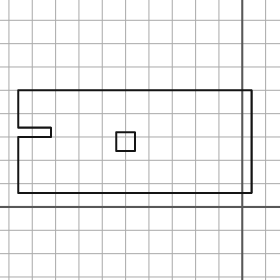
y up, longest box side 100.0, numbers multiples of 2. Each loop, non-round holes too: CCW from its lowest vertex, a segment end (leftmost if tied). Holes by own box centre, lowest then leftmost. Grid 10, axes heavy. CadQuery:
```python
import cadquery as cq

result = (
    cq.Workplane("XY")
    .moveTo(-96.0, 6.0)
    .lineTo(4.0, 6.0)
    .lineTo(4.0, 50.0)
    .lineTo(-96.0, 50.0)
    .lineTo(-96.0, 34.0)
    .lineTo(-82.0, 34.0)
    .lineTo(-82.0, 30.0)
    .lineTo(-96.0, 30.0)
    .close()
    .moveTo(-54.0, 24.0)
    .lineTo(-46.0, 24.0)
    .lineTo(-46.0, 32.0)
    .lineTo(-54.0, 32.0)
    .close()
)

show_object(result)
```